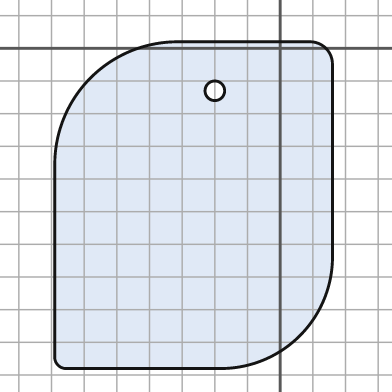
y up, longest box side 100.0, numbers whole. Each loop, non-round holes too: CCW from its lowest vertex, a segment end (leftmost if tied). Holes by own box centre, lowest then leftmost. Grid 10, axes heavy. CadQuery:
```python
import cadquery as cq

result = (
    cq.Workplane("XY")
    .moveTo(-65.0, -98.0)
    .lineTo(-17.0, -98.0)
    .threePointArc((6.0, -88.0), (16.0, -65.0))
    .lineTo(16.0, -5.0)
    .threePointArc((14.0, 0.0), (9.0, 2.0))
    .lineTo(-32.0, 2.0)
    .threePointArc((-58.0, -9.0), (-69.0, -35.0))
    .lineTo(-69.0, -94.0)
    .threePointArc((-68.0, -97.0), (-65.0, -98.0))
    .close()
    .moveTo(-20.0, -13.0)
    .circle(3.0)
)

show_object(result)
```